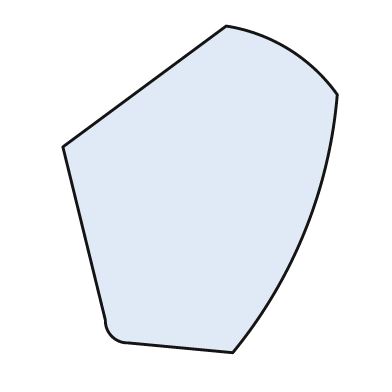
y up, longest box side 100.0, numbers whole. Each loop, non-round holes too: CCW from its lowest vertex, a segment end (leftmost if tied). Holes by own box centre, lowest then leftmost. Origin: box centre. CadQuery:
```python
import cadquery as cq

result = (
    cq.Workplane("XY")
    .moveTo(10.0, -50.0)
    .threePointArc((32.0, -13.0), (42.0, 29.0))
    .threePointArc((27.0, 43.0), (8.0, 50.0))
    .lineTo(-42.0, 13.0)
    .lineTo(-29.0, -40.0)
    .threePointArc((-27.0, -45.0), (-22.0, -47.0))
    .close()
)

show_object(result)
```